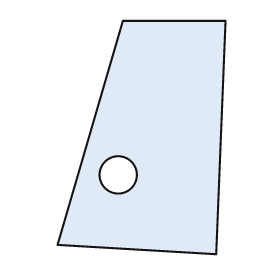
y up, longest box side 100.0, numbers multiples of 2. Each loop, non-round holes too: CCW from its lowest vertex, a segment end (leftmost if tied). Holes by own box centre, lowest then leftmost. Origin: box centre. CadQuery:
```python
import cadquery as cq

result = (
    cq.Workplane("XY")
    .moveTo(32.0, -50.0)
    .lineTo(36.0, 50.0)
    .lineTo(-8.0, 50.0)
    .lineTo(-36.0, -46.0)
    .close()
    .moveTo(-10.0, -16.0)
    .circle(8.0)
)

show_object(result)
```